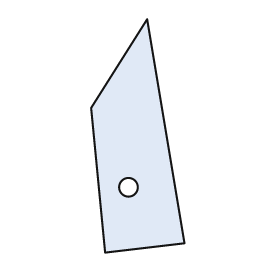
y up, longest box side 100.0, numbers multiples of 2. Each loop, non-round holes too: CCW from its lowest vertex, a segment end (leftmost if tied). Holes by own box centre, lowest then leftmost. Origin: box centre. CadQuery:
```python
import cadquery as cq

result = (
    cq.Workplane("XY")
    .moveTo(-14.0, -50.0)
    .lineTo(20.0, -46.0)
    .lineTo(4.0, 50.0)
    .lineTo(-20.0, 12.0)
    .close()
    .moveTo(-4.0, -22.0)
    .circle(4.0)
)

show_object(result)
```